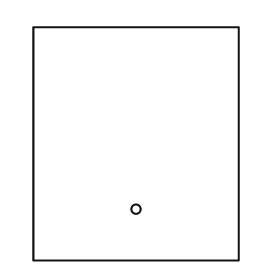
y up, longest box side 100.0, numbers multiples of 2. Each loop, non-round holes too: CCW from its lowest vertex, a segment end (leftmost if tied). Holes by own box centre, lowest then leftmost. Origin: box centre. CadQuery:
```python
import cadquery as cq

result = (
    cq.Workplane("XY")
    .moveTo(-44.0, -50.0)
    .lineTo(44.0, -50.0)
    .lineTo(44.0, 50.0)
    .lineTo(-44.0, 50.0)
    .close()
    .moveTo(0.0, -28.0)
    .circle(2.0)
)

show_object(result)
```